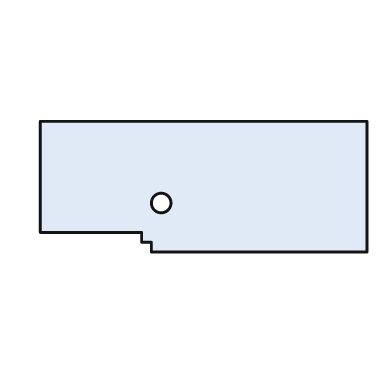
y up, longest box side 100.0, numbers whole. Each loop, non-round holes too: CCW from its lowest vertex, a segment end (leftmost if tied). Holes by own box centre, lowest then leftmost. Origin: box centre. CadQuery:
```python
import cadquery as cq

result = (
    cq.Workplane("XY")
    .moveTo(-16.0, -20.0)
    .lineTo(50.0, -20.0)
    .lineTo(50.0, 20.0)
    .lineTo(-50.0, 20.0)
    .lineTo(-50.0, -14.0)
    .lineTo(-19.0, -14.0)
    .lineTo(-19.0, -17.0)
    .lineTo(-16.0, -17.0)
    .close()
    .moveTo(-13.0, -5.0)
    .circle(3.0)
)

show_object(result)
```